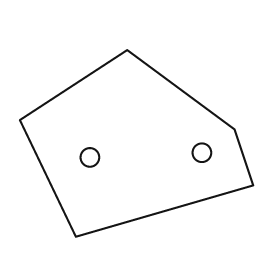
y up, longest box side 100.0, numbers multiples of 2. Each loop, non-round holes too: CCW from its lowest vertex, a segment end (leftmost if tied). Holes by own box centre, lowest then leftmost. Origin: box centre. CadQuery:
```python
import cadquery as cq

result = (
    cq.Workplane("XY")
    .moveTo(-26.0, -40.0)
    .lineTo(50.0, -18.0)
    .lineTo(42.0, 6.0)
    .lineTo(-4.0, 40.0)
    .lineTo(-50.0, 10.0)
    .close()
    .moveTo(-20.0, -6.0)
    .circle(4.0)
    .moveTo(28.0, -4.0)
    .circle(4.0)
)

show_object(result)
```